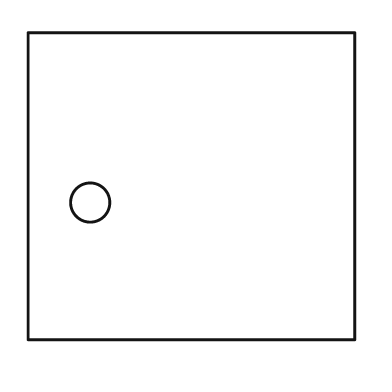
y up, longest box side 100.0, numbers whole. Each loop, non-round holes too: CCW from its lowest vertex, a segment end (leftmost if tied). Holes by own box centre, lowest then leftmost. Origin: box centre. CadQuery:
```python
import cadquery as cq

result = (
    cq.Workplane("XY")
    .moveTo(-50.0, -47.0)
    .lineTo(50.0, -47.0)
    .lineTo(50.0, 47.0)
    .lineTo(-50.0, 47.0)
    .close()
    .moveTo(-31.0, -5.0)
    .circle(6.0)
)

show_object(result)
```